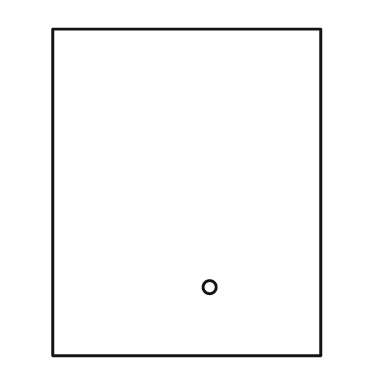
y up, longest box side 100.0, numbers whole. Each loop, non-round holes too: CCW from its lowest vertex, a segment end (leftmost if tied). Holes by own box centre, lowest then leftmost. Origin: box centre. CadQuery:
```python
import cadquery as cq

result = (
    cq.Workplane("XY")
    .moveTo(-41.0, -50.0)
    .lineTo(41.0, -50.0)
    .lineTo(41.0, 50.0)
    .lineTo(-41.0, 50.0)
    .close()
    .moveTo(7.0, -29.0)
    .circle(2.0)
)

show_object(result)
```